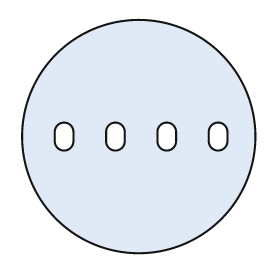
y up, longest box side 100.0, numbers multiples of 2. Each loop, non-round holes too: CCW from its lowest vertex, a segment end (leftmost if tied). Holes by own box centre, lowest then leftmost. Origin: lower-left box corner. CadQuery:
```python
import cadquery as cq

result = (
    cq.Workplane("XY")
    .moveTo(50.0, 50.0)
    .circle(50.0)
    .moveTo(14.0, 48.0)
    .threePointArc((18.0, 44.0), (22.0, 48.0))
    .lineTo(22.0, 52.0)
    .threePointArc((18.0, 56.0), (14.0, 52.0))
    .close()
    .moveTo(36.0, 48.0)
    .threePointArc((40.0, 44.0), (44.0, 48.0))
    .lineTo(44.0, 52.0)
    .threePointArc((40.0, 56.0), (36.0, 52.0))
    .close()
    .moveTo(58.0, 48.0)
    .threePointArc((62.0, 44.0), (66.0, 48.0))
    .lineTo(66.0, 52.0)
    .threePointArc((62.0, 56.0), (58.0, 52.0))
    .close()
    .moveTo(80.0, 48.0)
    .threePointArc((84.0, 44.0), (88.0, 48.0))
    .lineTo(88.0, 52.0)
    .threePointArc((84.0, 56.0), (80.0, 52.0))
    .close()
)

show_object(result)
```